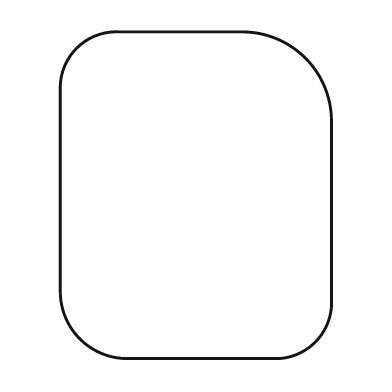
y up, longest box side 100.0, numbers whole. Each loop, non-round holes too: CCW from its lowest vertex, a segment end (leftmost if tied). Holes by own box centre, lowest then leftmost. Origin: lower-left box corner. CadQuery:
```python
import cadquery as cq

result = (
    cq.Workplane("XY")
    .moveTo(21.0, 0.0)
    .lineTo(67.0, 0.0)
    .threePointArc((78.0, 5.0), (83.0, 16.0))
    .lineTo(83.0, 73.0)
    .threePointArc((75.0, 92.0), (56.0, 100.0))
    .lineTo(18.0, 100.0)
    .threePointArc((5.0, 95.0), (0.0, 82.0))
    .lineTo(0.0, 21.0)
    .threePointArc((6.0, 6.0), (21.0, 0.0))
    .close()
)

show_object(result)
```